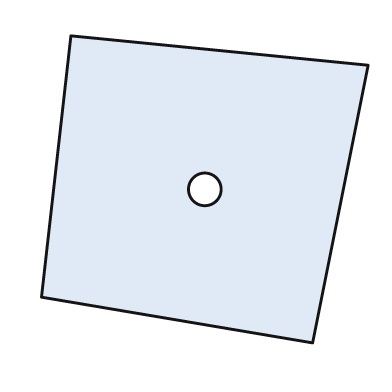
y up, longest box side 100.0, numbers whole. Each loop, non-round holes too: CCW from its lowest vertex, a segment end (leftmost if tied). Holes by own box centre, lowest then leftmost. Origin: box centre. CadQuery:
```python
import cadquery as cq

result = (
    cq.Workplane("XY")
    .moveTo(33.0, -47.0)
    .lineTo(50.0, 38.0)
    .lineTo(-41.0, 47.0)
    .lineTo(-50.0, -33.0)
    .close()
    .moveTo(0.0, 0.0)
    .circle(5.0)
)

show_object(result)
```